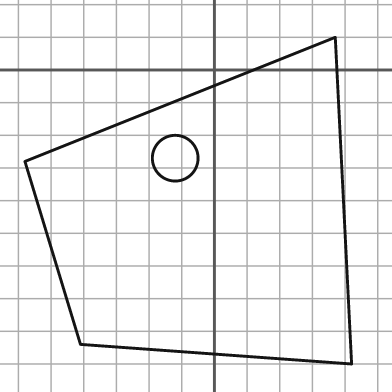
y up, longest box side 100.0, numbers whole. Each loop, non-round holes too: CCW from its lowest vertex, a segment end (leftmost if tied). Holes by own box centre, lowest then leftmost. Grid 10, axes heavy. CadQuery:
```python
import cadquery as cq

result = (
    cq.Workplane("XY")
    .moveTo(42.0, -90.0)
    .lineTo(37.0, 10.0)
    .lineTo(-58.0, -28.0)
    .lineTo(-41.0, -84.0)
    .close()
    .moveTo(-12.0, -27.0)
    .circle(7.0)
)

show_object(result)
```